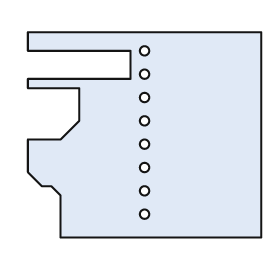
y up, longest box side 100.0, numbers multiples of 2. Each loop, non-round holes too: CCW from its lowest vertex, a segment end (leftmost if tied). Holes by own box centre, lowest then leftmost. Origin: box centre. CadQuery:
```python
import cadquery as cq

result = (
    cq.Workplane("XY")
    .moveTo(-36.0, -44.0)
    .lineTo(50.0, -44.0)
    .lineTo(50.0, 44.0)
    .lineTo(-50.0, 44.0)
    .lineTo(-50.0, 36.0)
    .lineTo(-6.0, 36.0)
    .lineTo(-6.0, 24.0)
    .lineTo(-50.0, 24.0)
    .lineTo(-50.0, 20.0)
    .lineTo(-28.0, 20.0)
    .lineTo(-28.0, 6.0)
    .lineTo(-36.0, -2.0)
    .lineTo(-50.0, -2.0)
    .lineTo(-50.0, -16.0)
    .lineTo(-44.0, -22.0)
    .lineTo(-40.0, -22.0)
    .lineTo(-36.0, -26.0)
    .close()
    .moveTo(0.0, -34.0)
    .circle(2.0)
    .moveTo(0.0, -24.0)
    .circle(2.0)
    .moveTo(0.0, -14.0)
    .circle(2.0)
    .moveTo(0.0, -4.0)
    .circle(2.0)
    .moveTo(0.0, 6.0)
    .circle(2.0)
    .moveTo(0.0, 16.0)
    .circle(2.0)
    .moveTo(0.0, 26.0)
    .circle(2.0)
    .moveTo(0.0, 36.0)
    .circle(2.0)
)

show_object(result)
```